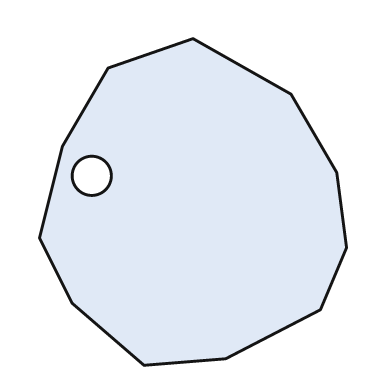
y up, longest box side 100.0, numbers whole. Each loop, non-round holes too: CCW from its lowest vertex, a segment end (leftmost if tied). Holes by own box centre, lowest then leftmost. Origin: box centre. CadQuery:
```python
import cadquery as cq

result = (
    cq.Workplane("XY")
    .moveTo(-15.0, -50.0)
    .lineTo(10.0, -48.0)
    .lineTo(39.0, -33.0)
    .lineTo(47.0, -14.0)
    .lineTo(44.0, 9.0)
    .lineTo(30.0, 33.0)
    .lineTo(0.0, 50.0)
    .lineTo(-26.0, 41.0)
    .lineTo(-40.0, 17.0)
    .lineTo(-47.0, -11.0)
    .lineTo(-37.0, -31.0)
    .close()
    .moveTo(-31.0, 8.0)
    .circle(6.0)
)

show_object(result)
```